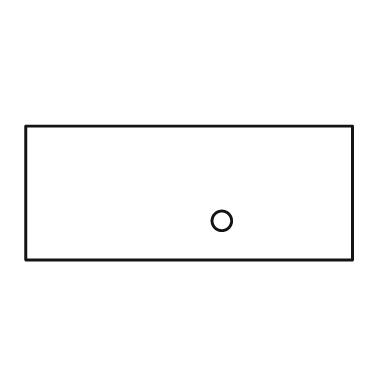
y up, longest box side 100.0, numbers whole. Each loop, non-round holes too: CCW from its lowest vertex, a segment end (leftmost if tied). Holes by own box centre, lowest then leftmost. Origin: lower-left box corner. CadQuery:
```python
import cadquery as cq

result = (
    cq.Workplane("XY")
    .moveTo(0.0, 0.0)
    .lineTo(100.0, 0.0)
    .lineTo(100.0, 41.0)
    .lineTo(0.0, 41.0)
    .close()
    .moveTo(60.0, 12.0)
    .circle(3.0)
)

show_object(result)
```